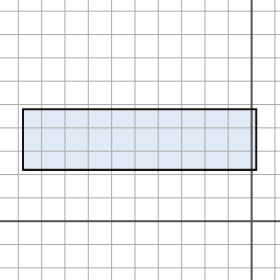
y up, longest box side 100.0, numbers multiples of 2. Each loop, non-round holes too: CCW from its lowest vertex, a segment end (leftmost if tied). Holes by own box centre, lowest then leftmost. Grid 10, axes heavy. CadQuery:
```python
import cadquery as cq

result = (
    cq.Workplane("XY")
    .moveTo(-98.0, 22.0)
    .lineTo(2.0, 22.0)
    .lineTo(2.0, 48.0)
    .lineTo(-98.0, 48.0)
    .close()
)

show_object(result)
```